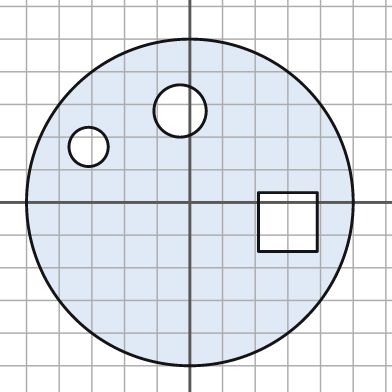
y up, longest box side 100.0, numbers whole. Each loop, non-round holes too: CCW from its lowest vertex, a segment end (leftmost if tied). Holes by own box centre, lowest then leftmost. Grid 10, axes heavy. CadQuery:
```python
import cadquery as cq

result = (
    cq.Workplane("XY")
    .moveTo(0.0, 0.0)
    .circle(50.0)
    .moveTo(21.0, -15.0)
    .lineTo(39.0, -15.0)
    .lineTo(39.0, 3.0)
    .lineTo(21.0, 3.0)
    .close()
    .moveTo(-31.0, 17.0)
    .circle(6.0)
    .moveTo(-3.0, 28.0)
    .circle(8.0)
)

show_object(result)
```